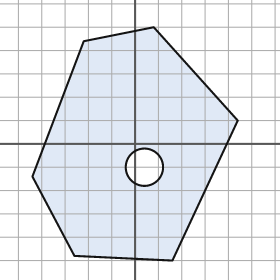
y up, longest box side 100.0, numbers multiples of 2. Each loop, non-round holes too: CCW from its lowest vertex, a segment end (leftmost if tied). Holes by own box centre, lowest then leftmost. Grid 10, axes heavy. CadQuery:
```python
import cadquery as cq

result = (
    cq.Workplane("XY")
    .moveTo(16.0, -50.0)
    .lineTo(44.0, 10.0)
    .lineTo(8.0, 50.0)
    .lineTo(-22.0, 44.0)
    .lineTo(-44.0, -14.0)
    .lineTo(-26.0, -48.0)
    .close()
    .moveTo(4.0, -10.0)
    .circle(8.0)
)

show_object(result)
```